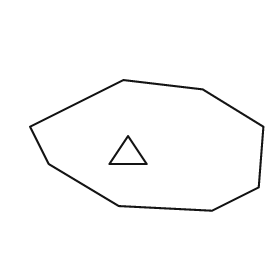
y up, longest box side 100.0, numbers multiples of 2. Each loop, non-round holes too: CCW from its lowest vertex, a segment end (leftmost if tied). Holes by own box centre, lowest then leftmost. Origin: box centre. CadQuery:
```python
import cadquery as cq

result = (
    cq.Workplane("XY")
    .moveTo(28.0, -28.0)
    .lineTo(48.0, -18.0)
    .lineTo(50.0, 8.0)
    .lineTo(24.0, 24.0)
    .lineTo(-10.0, 28.0)
    .lineTo(-50.0, 8.0)
    .lineTo(-42.0, -8.0)
    .lineTo(-12.0, -26.0)
    .close()
    .moveTo(-16.0, -8.0)
    .lineTo(0.0, -8.0)
    .lineTo(-8.0, 4.0)
    .close()
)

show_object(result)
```